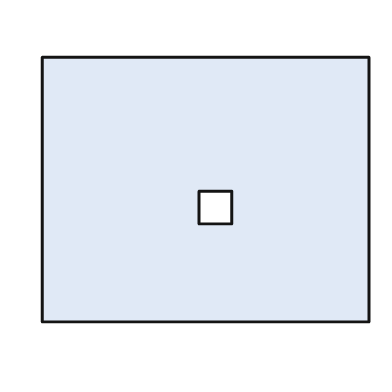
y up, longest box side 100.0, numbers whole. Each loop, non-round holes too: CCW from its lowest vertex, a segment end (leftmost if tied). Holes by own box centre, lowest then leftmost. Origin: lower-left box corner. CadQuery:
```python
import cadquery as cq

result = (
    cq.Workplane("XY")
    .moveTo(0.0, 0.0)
    .lineTo(100.0, 0.0)
    .lineTo(100.0, 81.0)
    .lineTo(0.0, 81.0)
    .close()
    .moveTo(48.0, 30.0)
    .lineTo(58.0, 30.0)
    .lineTo(58.0, 40.0)
    .lineTo(48.0, 40.0)
    .close()
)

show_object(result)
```